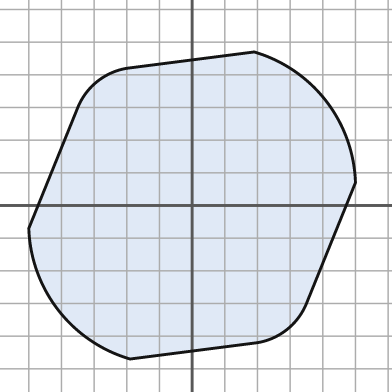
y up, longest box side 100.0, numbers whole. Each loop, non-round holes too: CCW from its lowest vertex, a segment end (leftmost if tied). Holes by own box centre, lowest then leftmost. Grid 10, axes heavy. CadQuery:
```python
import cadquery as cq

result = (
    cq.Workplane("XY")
    .moveTo(-19.0, -47.0)
    .lineTo(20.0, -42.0)
    .threePointArc((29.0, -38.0), (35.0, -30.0))
    .lineTo(50.0, 7.0)
    .threePointArc((41.0, 32.0), (19.0, 47.0))
    .lineTo(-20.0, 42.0)
    .threePointArc((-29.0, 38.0), (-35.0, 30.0))
    .lineTo(-50.0, -7.0)
    .threePointArc((-41.0, -32.0), (-19.0, -47.0))
    .close()
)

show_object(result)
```